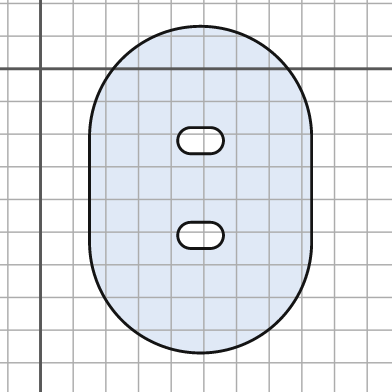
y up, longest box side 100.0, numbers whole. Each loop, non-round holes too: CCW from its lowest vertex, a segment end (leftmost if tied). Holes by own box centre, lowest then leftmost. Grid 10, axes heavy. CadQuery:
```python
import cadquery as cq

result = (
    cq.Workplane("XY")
    .moveTo(15.0, -53.0)
    .threePointArc((49.0, -87.0), (83.0, -53.0))
    .lineTo(83.0, -21.0)
    .threePointArc((49.0, 13.0), (15.0, -21.0))
    .close()
    .moveTo(46.0, -55.0)
    .lineTo(52.0, -55.0)
    .threePointArc((56.0, -51.0), (52.0, -47.0))
    .lineTo(46.0, -47.0)
    .threePointArc((42.0, -51.0), (46.0, -55.0))
    .close()
    .moveTo(46.0, -26.0)
    .lineTo(52.0, -26.0)
    .threePointArc((56.0, -22.0), (52.0, -18.0))
    .lineTo(46.0, -18.0)
    .threePointArc((42.0, -22.0), (46.0, -26.0))
    .close()
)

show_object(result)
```